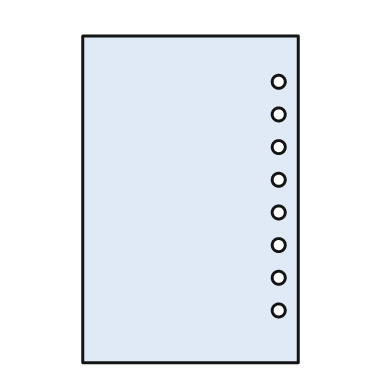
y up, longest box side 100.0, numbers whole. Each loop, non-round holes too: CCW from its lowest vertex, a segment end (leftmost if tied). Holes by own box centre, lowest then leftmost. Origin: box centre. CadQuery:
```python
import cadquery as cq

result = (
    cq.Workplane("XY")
    .moveTo(-33.0, -50.0)
    .lineTo(33.0, -50.0)
    .lineTo(33.0, 50.0)
    .lineTo(-33.0, 50.0)
    .close()
    .moveTo(27.0, -34.0)
    .circle(2.0)
    .moveTo(27.0, -24.0)
    .circle(2.0)
    .moveTo(27.0, -14.0)
    .circle(2.0)
    .moveTo(27.0, -4.0)
    .circle(2.0)
    .moveTo(27.0, 6.0)
    .circle(2.0)
    .moveTo(27.0, 16.0)
    .circle(2.0)
    .moveTo(27.0, 26.0)
    .circle(2.0)
    .moveTo(27.0, 36.0)
    .circle(2.0)
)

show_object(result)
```